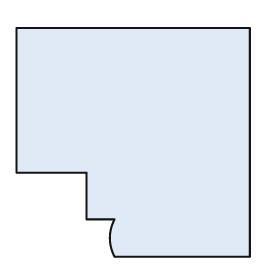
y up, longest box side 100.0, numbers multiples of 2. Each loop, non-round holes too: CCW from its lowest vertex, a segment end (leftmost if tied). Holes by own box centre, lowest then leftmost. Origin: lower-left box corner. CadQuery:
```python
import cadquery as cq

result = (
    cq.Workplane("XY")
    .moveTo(42.0, 0.0)
    .lineTo(100.0, 0.0)
    .lineTo(100.0, 98.0)
    .lineTo(0.0, 98.0)
    .lineTo(0.0, 36.0)
    .lineTo(30.0, 36.0)
    .lineTo(30.0, 16.0)
    .lineTo(42.0, 16.0)
    .threePointArc((40.0, 8.0), (42.0, 0.0))
    .close()
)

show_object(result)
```